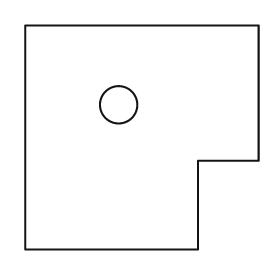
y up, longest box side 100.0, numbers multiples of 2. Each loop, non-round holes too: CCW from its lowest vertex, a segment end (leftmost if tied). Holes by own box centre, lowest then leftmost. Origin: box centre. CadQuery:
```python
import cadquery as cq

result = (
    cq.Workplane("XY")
    .moveTo(-50.0, -48.0)
    .lineTo(24.0, -48.0)
    .lineTo(24.0, -10.0)
    .lineTo(50.0, -10.0)
    .lineTo(50.0, 48.0)
    .lineTo(-50.0, 48.0)
    .close()
    .moveTo(-10.0, 14.0)
    .circle(8.0)
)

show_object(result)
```